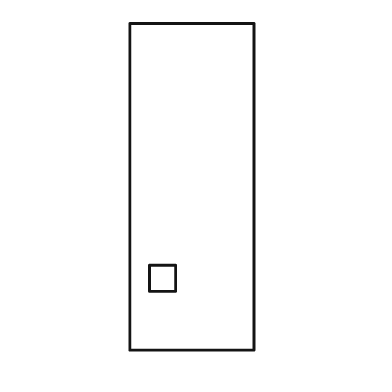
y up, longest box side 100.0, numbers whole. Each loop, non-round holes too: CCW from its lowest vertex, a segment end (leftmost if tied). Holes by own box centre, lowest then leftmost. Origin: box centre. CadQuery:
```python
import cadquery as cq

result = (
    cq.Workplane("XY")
    .moveTo(-19.0, -50.0)
    .lineTo(19.0, -50.0)
    .lineTo(19.0, 50.0)
    .lineTo(-19.0, 50.0)
    .close()
    .moveTo(-13.0, -32.0)
    .lineTo(-5.0, -32.0)
    .lineTo(-5.0, -24.0)
    .lineTo(-13.0, -24.0)
    .close()
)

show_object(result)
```